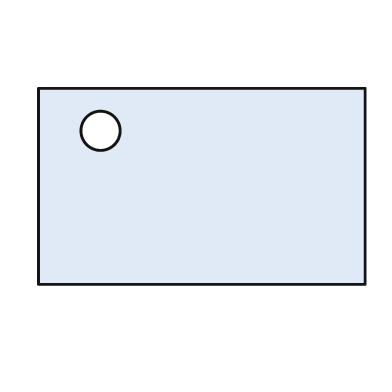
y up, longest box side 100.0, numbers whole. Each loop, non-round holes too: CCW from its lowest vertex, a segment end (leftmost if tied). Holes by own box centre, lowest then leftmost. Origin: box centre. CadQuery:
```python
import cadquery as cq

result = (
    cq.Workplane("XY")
    .moveTo(-50.0, -30.0)
    .lineTo(50.0, -30.0)
    .lineTo(50.0, 30.0)
    .lineTo(-50.0, 30.0)
    .close()
    .moveTo(-31.0, 17.0)
    .circle(6.0)
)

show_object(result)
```